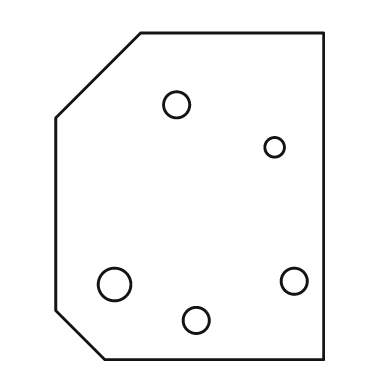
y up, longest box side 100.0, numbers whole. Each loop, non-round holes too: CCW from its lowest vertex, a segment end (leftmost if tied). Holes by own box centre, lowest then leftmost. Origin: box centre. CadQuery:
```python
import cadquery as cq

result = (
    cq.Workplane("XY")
    .moveTo(-26.0, -50.0)
    .lineTo(41.0, -50.0)
    .lineTo(41.0, 50.0)
    .lineTo(-15.0, 50.0)
    .lineTo(-41.0, 24.0)
    .lineTo(-41.0, -35.0)
    .close()
    .moveTo(2.0, -38.0)
    .circle(4.0)
    .moveTo(-23.0, -27.0)
    .circle(5.0)
    .moveTo(32.0, -26.0)
    .circle(4.0)
    .moveTo(26.0, 15.0)
    .circle(3.0)
    .moveTo(-4.0, 28.0)
    .circle(4.0)
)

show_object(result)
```